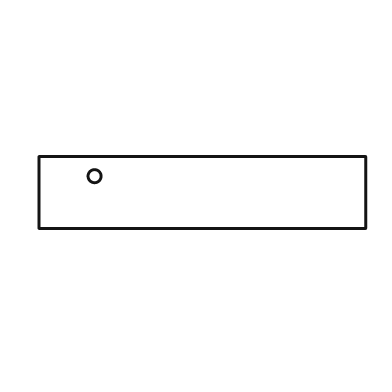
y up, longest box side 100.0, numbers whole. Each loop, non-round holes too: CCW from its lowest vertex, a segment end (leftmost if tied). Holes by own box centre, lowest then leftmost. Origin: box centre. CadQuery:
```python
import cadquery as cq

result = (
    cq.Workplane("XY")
    .moveTo(-50.0, -11.0)
    .lineTo(50.0, -11.0)
    .lineTo(50.0, 11.0)
    .lineTo(-50.0, 11.0)
    .close()
    .moveTo(-33.0, 5.0)
    .circle(2.0)
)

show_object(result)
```